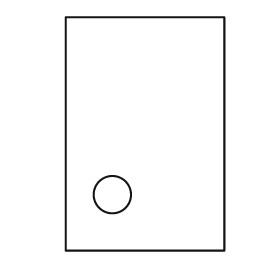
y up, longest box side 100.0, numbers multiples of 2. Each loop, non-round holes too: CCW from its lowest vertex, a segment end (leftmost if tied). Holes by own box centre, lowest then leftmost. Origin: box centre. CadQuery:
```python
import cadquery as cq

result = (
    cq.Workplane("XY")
    .moveTo(-34.0, -50.0)
    .lineTo(34.0, -50.0)
    .lineTo(34.0, 50.0)
    .lineTo(-34.0, 50.0)
    .close()
    .moveTo(-14.0, -26.0)
    .circle(8.0)
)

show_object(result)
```